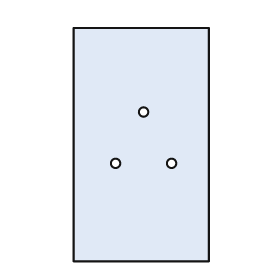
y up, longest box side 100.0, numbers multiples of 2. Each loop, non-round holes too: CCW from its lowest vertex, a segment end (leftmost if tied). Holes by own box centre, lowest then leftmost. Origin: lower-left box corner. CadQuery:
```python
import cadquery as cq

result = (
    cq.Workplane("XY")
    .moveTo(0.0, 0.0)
    .lineTo(58.0, 0.0)
    .lineTo(58.0, 100.0)
    .lineTo(0.0, 100.0)
    .close()
    .moveTo(18.0, 42.0)
    .circle(2.0)
    .moveTo(42.0, 42.0)
    .circle(2.0)
    .moveTo(30.0, 64.0)
    .circle(2.0)
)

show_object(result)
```